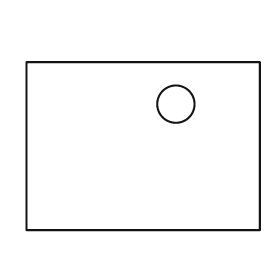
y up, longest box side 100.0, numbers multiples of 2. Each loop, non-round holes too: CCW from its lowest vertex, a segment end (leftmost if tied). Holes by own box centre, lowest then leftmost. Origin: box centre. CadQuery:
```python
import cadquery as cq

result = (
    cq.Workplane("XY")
    .moveTo(-50.0, -36.0)
    .lineTo(50.0, -36.0)
    .lineTo(50.0, 36.0)
    .lineTo(-50.0, 36.0)
    .close()
    .moveTo(14.0, 18.0)
    .circle(8.0)
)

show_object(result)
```